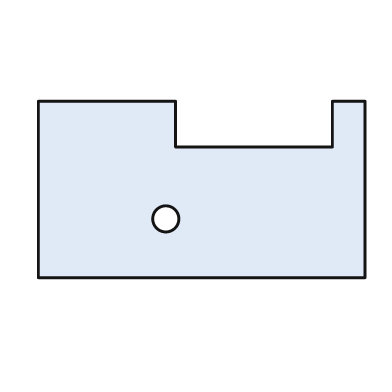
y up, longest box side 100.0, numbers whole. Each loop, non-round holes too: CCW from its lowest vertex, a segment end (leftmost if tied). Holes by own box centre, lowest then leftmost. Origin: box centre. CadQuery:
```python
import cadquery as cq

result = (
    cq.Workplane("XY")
    .moveTo(-50.0, -27.0)
    .lineTo(50.0, -27.0)
    .lineTo(50.0, 27.0)
    .lineTo(40.0, 27.0)
    .lineTo(40.0, 13.0)
    .lineTo(-8.0, 13.0)
    .lineTo(-8.0, 27.0)
    .lineTo(-50.0, 27.0)
    .close()
    .moveTo(-11.0, -9.0)
    .circle(4.0)
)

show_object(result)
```